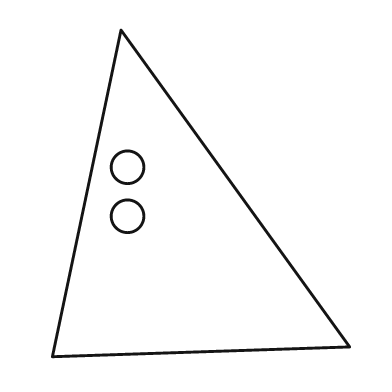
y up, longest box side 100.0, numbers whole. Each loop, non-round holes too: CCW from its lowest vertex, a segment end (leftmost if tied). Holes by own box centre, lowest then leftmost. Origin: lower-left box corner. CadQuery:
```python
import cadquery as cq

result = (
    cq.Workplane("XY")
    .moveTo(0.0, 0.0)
    .lineTo(91.0, 3.0)
    .lineTo(21.0, 100.0)
    .close()
    .moveTo(23.0, 43.0)
    .circle(5.0)
    .moveTo(23.0, 58.0)
    .circle(5.0)
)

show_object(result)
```